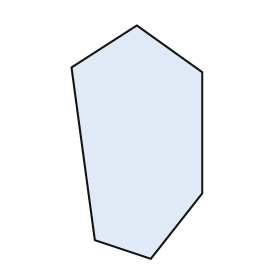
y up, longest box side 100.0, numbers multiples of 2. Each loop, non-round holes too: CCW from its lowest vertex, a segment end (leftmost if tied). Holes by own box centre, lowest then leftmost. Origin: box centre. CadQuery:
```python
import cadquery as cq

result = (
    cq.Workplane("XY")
    .moveTo(6.0, -50.0)
    .lineTo(28.0, -22.0)
    .lineTo(28.0, 30.0)
    .lineTo(0.0, 50.0)
    .lineTo(-28.0, 32.0)
    .lineTo(-18.0, -42.0)
    .close()
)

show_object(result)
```